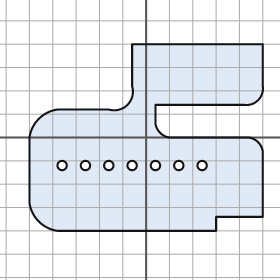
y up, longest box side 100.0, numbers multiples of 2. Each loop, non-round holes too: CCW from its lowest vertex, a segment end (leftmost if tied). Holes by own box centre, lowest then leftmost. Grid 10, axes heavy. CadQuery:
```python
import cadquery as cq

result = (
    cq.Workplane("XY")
    .moveTo(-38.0, -40.0)
    .lineTo(30.0, -40.0)
    .lineTo(30.0, -34.0)
    .lineTo(50.0, -34.0)
    .lineTo(50.0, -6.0)
    .threePointArc((48.0, -2.0), (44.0, 0.0))
    .lineTo(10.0, 0.0)
    .threePointArc((6.0, 2.0), (4.0, 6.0))
    .lineTo(4.0, 14.0)
    .lineTo(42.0, 14.0)
    .threePointArc((48.0, 16.0), (50.0, 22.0))
    .lineTo(50.0, 40.0)
    .lineTo(-6.0, 40.0)
    .lineTo(-6.0, 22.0)
    .threePointArc((-8.0, 14.0), (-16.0, 12.0))
    .lineTo(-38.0, 12.0)
    .threePointArc((-46.0, 8.0), (-50.0, 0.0))
    .lineTo(-50.0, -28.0)
    .threePointArc((-46.0, -36.0), (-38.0, -40.0))
    .close()
    .moveTo(-36.0, -12.0)
    .circle(2.0)
    .moveTo(-26.0, -12.0)
    .circle(2.0)
    .moveTo(-16.0, -12.0)
    .circle(2.0)
    .moveTo(-6.0, -12.0)
    .circle(2.0)
    .moveTo(4.0, -12.0)
    .circle(2.0)
    .moveTo(14.0, -12.0)
    .circle(2.0)
    .moveTo(24.0, -12.0)
    .circle(2.0)
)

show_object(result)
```